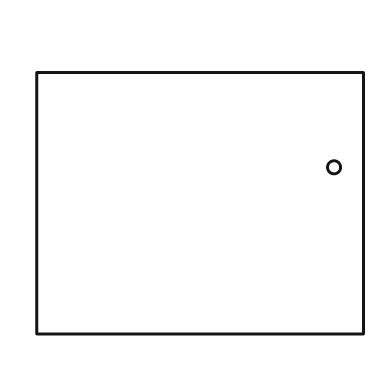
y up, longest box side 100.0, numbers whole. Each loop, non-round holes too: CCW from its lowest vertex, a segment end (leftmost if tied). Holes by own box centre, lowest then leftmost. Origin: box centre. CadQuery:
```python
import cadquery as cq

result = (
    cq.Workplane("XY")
    .moveTo(-50.0, -40.0)
    .lineTo(50.0, -40.0)
    .lineTo(50.0, 40.0)
    .lineTo(-50.0, 40.0)
    .close()
    .moveTo(41.0, 11.0)
    .circle(2.0)
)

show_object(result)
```